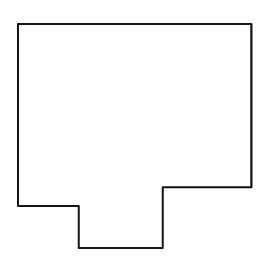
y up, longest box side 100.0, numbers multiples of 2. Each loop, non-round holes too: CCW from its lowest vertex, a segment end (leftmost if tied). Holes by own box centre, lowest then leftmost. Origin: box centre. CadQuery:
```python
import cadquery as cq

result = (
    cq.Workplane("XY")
    .moveTo(-24.0, -48.0)
    .lineTo(12.0, -48.0)
    .lineTo(12.0, -22.0)
    .lineTo(50.0, -22.0)
    .lineTo(50.0, 48.0)
    .lineTo(-50.0, 48.0)
    .lineTo(-50.0, -30.0)
    .lineTo(-24.0, -30.0)
    .close()
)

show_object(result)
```